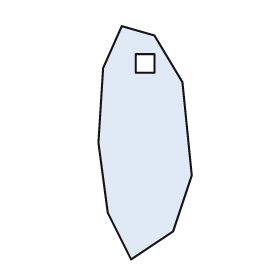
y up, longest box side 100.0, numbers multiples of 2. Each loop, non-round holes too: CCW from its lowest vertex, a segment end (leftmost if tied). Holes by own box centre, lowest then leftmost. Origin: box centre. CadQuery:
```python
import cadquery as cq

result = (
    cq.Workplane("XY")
    .moveTo(-6.0, -50.0)
    .lineTo(12.0, -38.0)
    .lineTo(20.0, -14.0)
    .lineTo(16.0, 26.0)
    .lineTo(4.0, 46.0)
    .lineTo(-10.0, 50.0)
    .lineTo(-18.0, 32.0)
    .lineTo(-20.0, 0.0)
    .lineTo(-16.0, -30.0)
    .close()
    .moveTo(-4.0, 30.0)
    .lineTo(4.0, 30.0)
    .lineTo(4.0, 38.0)
    .lineTo(-4.0, 38.0)
    .close()
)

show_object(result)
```